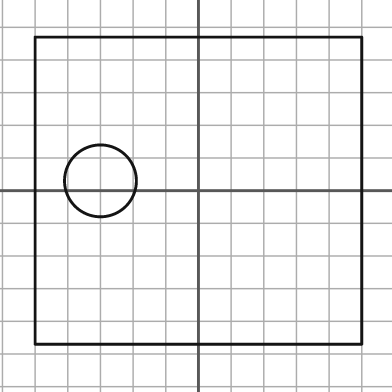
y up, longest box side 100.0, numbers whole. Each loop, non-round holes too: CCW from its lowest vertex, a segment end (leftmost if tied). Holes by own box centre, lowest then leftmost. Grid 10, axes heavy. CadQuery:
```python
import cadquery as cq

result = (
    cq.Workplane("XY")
    .moveTo(-50.0, -47.0)
    .lineTo(50.0, -47.0)
    .lineTo(50.0, 47.0)
    .lineTo(-50.0, 47.0)
    .close()
    .moveTo(-30.0, 3.0)
    .circle(11.0)
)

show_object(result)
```